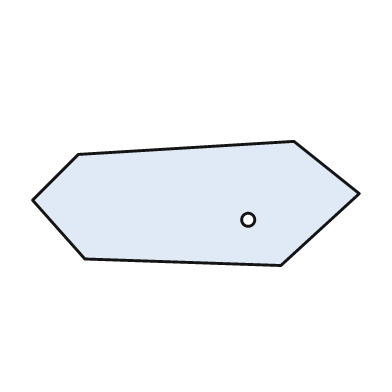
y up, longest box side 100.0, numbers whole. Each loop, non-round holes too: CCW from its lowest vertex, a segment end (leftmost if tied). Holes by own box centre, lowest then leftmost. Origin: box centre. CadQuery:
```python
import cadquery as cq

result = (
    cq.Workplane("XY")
    .moveTo(26.0, -19.0)
    .lineTo(50.0, 3.0)
    .lineTo(30.0, 19.0)
    .lineTo(-36.0, 15.0)
    .lineTo(-50.0, 1.0)
    .lineTo(-34.0, -17.0)
    .close()
    .moveTo(16.0, -5.0)
    .circle(2.0)
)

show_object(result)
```